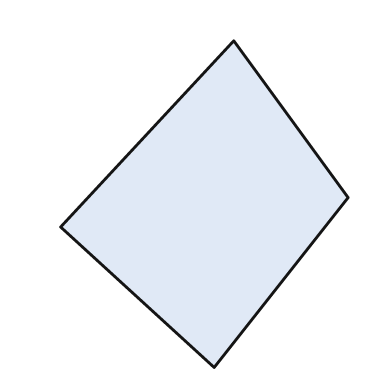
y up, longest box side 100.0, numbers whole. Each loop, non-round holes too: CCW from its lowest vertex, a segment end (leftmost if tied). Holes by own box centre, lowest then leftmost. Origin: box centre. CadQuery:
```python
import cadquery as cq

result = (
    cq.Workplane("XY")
    .moveTo(3.0, -50.0)
    .lineTo(44.0, 2.0)
    .lineTo(9.0, 50.0)
    .lineTo(-44.0, -7.0)
    .close()
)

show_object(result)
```